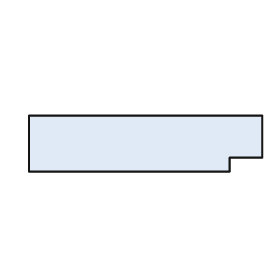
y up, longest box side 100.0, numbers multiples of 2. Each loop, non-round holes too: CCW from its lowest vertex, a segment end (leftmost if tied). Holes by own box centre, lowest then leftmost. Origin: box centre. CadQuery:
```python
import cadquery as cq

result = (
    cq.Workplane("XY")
    .moveTo(-50.0, -12.0)
    .lineTo(36.0, -12.0)
    .lineTo(36.0, -6.0)
    .lineTo(50.0, -6.0)
    .lineTo(50.0, 12.0)
    .lineTo(-50.0, 12.0)
    .close()
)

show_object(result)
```